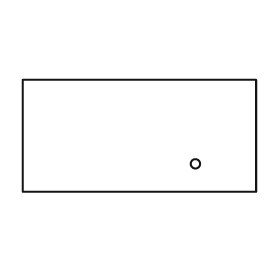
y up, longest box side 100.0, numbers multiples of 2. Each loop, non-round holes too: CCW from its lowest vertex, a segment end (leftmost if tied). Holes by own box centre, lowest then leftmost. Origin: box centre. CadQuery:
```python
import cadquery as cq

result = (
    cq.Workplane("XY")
    .moveTo(-50.0, -24.0)
    .lineTo(50.0, -24.0)
    .lineTo(50.0, 24.0)
    .lineTo(-50.0, 24.0)
    .close()
    .moveTo(24.0, -12.0)
    .circle(2.0)
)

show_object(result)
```